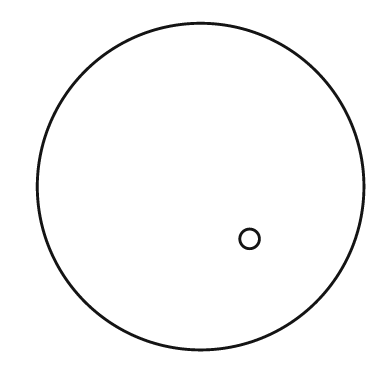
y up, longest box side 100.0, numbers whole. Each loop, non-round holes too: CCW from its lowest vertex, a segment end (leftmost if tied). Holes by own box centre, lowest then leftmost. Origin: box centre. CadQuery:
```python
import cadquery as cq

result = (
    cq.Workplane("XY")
    .moveTo(0.0, 0.0)
    .circle(50.0)
    .moveTo(15.0, -16.0)
    .circle(3.0)
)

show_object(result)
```